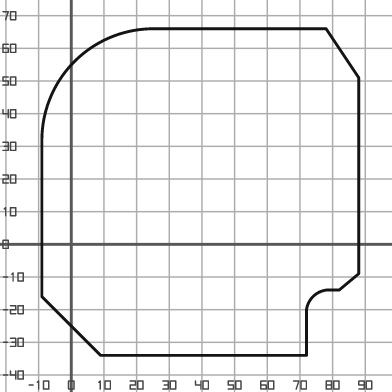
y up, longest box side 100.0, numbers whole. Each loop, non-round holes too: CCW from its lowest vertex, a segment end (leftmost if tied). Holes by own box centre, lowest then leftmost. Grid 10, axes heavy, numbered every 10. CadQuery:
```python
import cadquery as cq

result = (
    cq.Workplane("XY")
    .moveTo(9.0, -34.0)
    .lineTo(72.0, -34.0)
    .lineTo(72.0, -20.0)
    .threePointArc((74.0, -16.0), (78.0, -14.0))
    .lineTo(82.0, -14.0)
    .lineTo(88.0, -9.0)
    .lineTo(88.0, 51.0)
    .lineTo(78.0, 66.0)
    .lineTo(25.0, 66.0)
    .threePointArc((1.0, 56.0), (-9.0, 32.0))
    .lineTo(-9.0, -16.0)
    .close()
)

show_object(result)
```